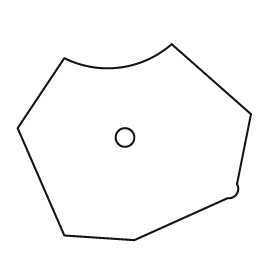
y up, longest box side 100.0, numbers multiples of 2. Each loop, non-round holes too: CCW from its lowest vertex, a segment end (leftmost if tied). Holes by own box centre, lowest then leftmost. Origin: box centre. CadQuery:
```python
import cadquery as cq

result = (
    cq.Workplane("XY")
    .moveTo(0.0, -42.0)
    .lineTo(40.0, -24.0)
    .threePointArc((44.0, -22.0), (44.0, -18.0))
    .lineTo(50.0, 12.0)
    .lineTo(16.0, 42.0)
    .threePointArc((-6.0, 32.0), (-30.0, 36.0))
    .lineTo(-50.0, 6.0)
    .lineTo(-30.0, -40.0)
    .close()
    .moveTo(-4.0, 2.0)
    .circle(4.0)
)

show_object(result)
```